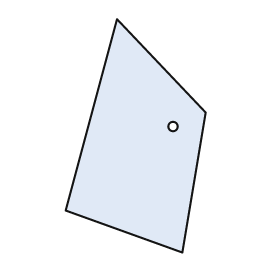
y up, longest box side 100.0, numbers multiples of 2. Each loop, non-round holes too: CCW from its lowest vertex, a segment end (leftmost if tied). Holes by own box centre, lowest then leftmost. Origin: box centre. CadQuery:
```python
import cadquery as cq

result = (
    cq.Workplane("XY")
    .moveTo(20.0, -50.0)
    .lineTo(30.0, 10.0)
    .lineTo(-8.0, 50.0)
    .lineTo(-30.0, -32.0)
    .close()
    .moveTo(16.0, 4.0)
    .circle(2.0)
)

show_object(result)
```